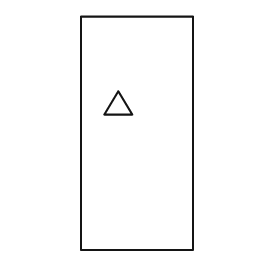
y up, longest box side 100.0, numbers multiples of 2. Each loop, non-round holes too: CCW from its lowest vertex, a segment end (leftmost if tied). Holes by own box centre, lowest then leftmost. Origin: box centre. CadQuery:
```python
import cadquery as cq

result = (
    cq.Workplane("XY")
    .moveTo(-24.0, -50.0)
    .lineTo(24.0, -50.0)
    .lineTo(24.0, 50.0)
    .lineTo(-24.0, 50.0)
    .close()
    .moveTo(-14.0, 8.0)
    .lineTo(-2.0, 8.0)
    .lineTo(-8.0, 18.0)
    .close()
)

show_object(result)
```